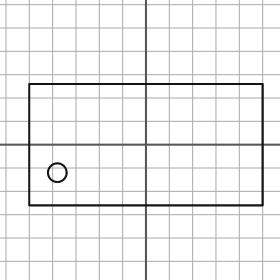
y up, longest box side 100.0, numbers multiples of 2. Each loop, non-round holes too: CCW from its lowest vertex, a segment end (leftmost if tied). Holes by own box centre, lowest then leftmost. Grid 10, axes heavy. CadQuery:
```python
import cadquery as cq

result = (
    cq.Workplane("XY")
    .moveTo(-50.0, -26.0)
    .lineTo(50.0, -26.0)
    .lineTo(50.0, 26.0)
    .lineTo(-50.0, 26.0)
    .close()
    .moveTo(-38.0, -12.0)
    .circle(4.0)
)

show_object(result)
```